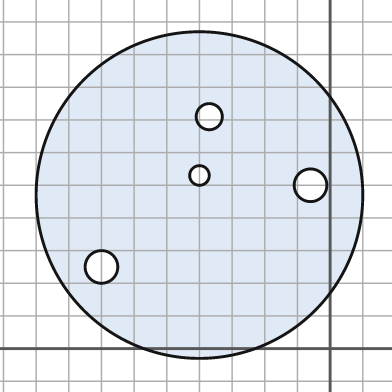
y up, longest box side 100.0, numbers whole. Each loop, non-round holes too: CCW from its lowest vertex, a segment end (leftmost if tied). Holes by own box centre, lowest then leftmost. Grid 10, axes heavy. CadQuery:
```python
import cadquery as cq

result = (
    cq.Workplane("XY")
    .moveTo(-40.0, 47.0)
    .circle(50.0)
    .moveTo(-70.0, 25.0)
    .circle(5.0)
    .moveTo(-6.0, 50.0)
    .circle(5.0)
    .moveTo(-40.0, 53.0)
    .circle(3.0)
    .moveTo(-37.0, 71.0)
    .circle(4.0)
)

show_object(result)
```